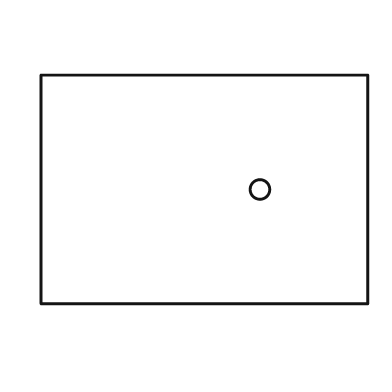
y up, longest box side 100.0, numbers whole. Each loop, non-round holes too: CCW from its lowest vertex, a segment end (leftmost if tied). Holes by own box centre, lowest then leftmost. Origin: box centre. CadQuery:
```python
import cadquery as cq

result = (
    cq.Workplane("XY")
    .moveTo(-50.0, -35.0)
    .lineTo(50.0, -35.0)
    .lineTo(50.0, 35.0)
    .lineTo(-50.0, 35.0)
    .close()
    .moveTo(17.0, 0.0)
    .circle(3.0)
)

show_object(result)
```